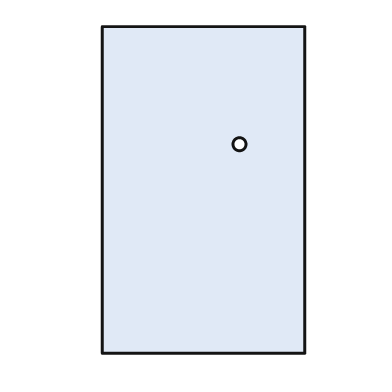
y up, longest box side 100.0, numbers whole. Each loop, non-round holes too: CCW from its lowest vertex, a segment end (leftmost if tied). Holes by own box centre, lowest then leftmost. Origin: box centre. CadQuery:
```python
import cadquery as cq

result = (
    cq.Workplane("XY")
    .moveTo(-31.0, -50.0)
    .lineTo(31.0, -50.0)
    .lineTo(31.0, 50.0)
    .lineTo(-31.0, 50.0)
    .close()
    .moveTo(11.0, 14.0)
    .circle(2.0)
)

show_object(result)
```